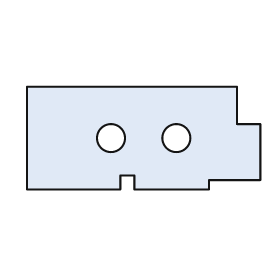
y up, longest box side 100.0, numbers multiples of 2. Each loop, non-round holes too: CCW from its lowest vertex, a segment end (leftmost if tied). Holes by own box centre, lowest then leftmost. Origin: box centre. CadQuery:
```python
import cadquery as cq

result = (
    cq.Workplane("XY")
    .moveTo(-50.0, -22.0)
    .lineTo(-10.0, -22.0)
    .lineTo(-10.0, -16.0)
    .lineTo(-4.0, -16.0)
    .lineTo(-4.0, -22.0)
    .lineTo(28.0, -22.0)
    .lineTo(28.0, -18.0)
    .lineTo(50.0, -18.0)
    .lineTo(50.0, 6.0)
    .lineTo(40.0, 6.0)
    .lineTo(40.0, 22.0)
    .lineTo(-50.0, 22.0)
    .close()
    .moveTo(-14.0, 0.0)
    .circle(6.0)
    .moveTo(14.0, 0.0)
    .circle(6.0)
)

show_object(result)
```